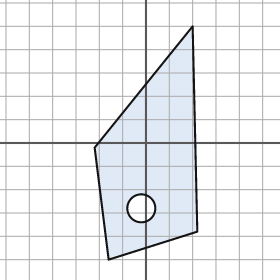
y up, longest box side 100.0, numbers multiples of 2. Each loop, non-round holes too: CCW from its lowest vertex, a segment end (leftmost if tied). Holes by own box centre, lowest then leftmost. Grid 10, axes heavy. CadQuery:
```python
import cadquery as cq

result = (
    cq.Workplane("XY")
    .moveTo(-16.0, -50.0)
    .lineTo(22.0, -38.0)
    .lineTo(20.0, 50.0)
    .lineTo(-22.0, -2.0)
    .close()
    .moveTo(-2.0, -28.0)
    .circle(6.0)
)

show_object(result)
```